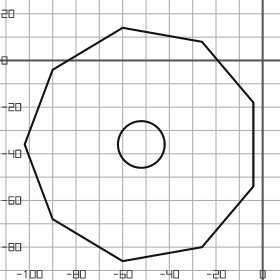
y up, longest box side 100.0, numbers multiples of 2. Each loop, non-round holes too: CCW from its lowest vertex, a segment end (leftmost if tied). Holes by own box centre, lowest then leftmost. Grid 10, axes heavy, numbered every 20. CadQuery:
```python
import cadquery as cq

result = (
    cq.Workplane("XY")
    .moveTo(-60.0, -86.0)
    .lineTo(-26.0, -80.0)
    .lineTo(-4.0, -54.0)
    .lineTo(-4.0, -18.0)
    .lineTo(-26.0, 8.0)
    .lineTo(-60.0, 14.0)
    .lineTo(-90.0, -4.0)
    .lineTo(-102.0, -36.0)
    .lineTo(-90.0, -68.0)
    .close()
    .moveTo(-52.0, -36.0)
    .circle(10.0)
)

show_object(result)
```